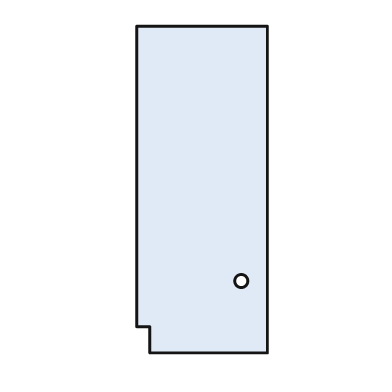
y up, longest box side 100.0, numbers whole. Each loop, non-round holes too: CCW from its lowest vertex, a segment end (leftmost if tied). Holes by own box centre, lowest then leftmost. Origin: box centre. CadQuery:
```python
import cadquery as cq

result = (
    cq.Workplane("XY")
    .moveTo(-16.0, -50.0)
    .lineTo(20.0, -50.0)
    .lineTo(20.0, 50.0)
    .lineTo(-20.0, 50.0)
    .lineTo(-20.0, -42.0)
    .lineTo(-16.0, -42.0)
    .close()
    .moveTo(12.0, -28.0)
    .circle(2.0)
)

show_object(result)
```